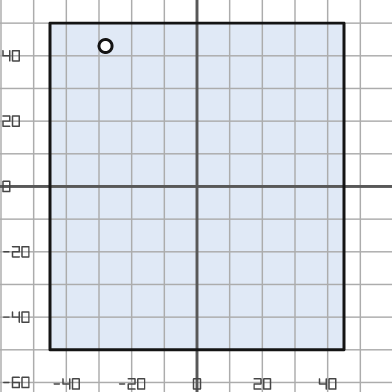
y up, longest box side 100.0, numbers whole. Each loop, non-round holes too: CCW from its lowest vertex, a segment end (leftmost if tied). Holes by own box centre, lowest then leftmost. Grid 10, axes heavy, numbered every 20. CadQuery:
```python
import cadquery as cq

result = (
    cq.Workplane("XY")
    .moveTo(-45.0, -50.0)
    .lineTo(45.0, -50.0)
    .lineTo(45.0, 50.0)
    .lineTo(-45.0, 50.0)
    .close()
    .moveTo(-28.0, 43.0)
    .circle(2.0)
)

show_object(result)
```